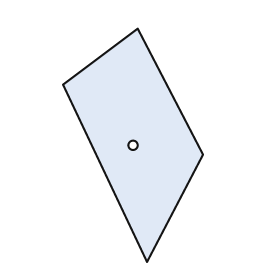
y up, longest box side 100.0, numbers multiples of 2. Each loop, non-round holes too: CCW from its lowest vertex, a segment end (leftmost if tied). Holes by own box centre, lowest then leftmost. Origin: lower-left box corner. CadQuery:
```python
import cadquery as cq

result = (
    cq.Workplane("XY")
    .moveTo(36.0, 0.0)
    .lineTo(60.0, 46.0)
    .lineTo(32.0, 100.0)
    .lineTo(0.0, 76.0)
    .close()
    .moveTo(30.0, 50.0)
    .circle(2.0)
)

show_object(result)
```